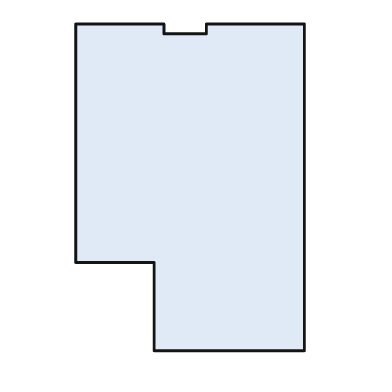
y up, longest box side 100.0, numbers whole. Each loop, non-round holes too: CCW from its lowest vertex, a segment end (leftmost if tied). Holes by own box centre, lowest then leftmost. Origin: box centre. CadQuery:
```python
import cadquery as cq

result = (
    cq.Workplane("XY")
    .moveTo(-11.0, -50.0)
    .lineTo(35.0, -50.0)
    .lineTo(35.0, 50.0)
    .lineTo(5.0, 50.0)
    .lineTo(5.0, 47.0)
    .lineTo(-8.0, 47.0)
    .lineTo(-8.0, 50.0)
    .lineTo(-35.0, 50.0)
    .lineTo(-35.0, -23.0)
    .lineTo(-11.0, -23.0)
    .close()
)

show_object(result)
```